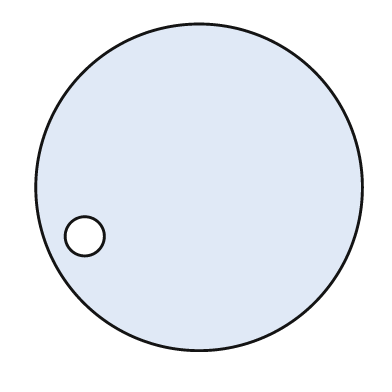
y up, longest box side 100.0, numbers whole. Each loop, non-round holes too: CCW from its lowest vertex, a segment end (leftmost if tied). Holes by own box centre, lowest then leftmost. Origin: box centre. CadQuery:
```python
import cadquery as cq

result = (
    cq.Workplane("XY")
    .moveTo(0.0, 0.0)
    .circle(50.0)
    .moveTo(-35.0, -15.0)
    .circle(6.0)
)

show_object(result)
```